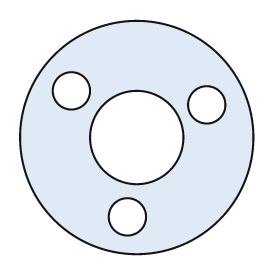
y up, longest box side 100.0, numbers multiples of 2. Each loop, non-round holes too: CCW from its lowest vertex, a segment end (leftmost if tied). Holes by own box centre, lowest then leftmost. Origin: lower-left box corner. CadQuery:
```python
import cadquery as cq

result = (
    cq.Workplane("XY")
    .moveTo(50.0, 50.0)
    .circle(50.0)
    .moveTo(46.0, 16.0)
    .circle(8.0)
    .moveTo(50.0, 50.0)
    .circle(20.0)
    .moveTo(80.0, 64.0)
    .circle(8.0)
    .moveTo(22.0, 70.0)
    .circle(8.0)
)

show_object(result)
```